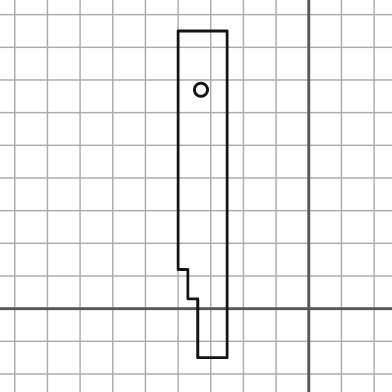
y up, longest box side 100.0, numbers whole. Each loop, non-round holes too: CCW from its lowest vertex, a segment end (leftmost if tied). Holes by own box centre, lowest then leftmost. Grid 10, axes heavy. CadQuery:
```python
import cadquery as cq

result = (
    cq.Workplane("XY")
    .moveTo(-34.0, -15.0)
    .lineTo(-25.0, -15.0)
    .lineTo(-25.0, 85.0)
    .lineTo(-40.0, 85.0)
    .lineTo(-40.0, 12.0)
    .lineTo(-37.0, 12.0)
    .lineTo(-37.0, 3.0)
    .lineTo(-34.0, 3.0)
    .close()
    .moveTo(-33.0, 67.0)
    .circle(2.0)
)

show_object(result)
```